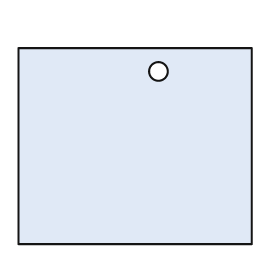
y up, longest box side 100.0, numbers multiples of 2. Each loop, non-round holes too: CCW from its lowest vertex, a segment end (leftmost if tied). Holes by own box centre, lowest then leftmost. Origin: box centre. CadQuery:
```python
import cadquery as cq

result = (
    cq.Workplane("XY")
    .moveTo(-50.0, -42.0)
    .lineTo(50.0, -42.0)
    .lineTo(50.0, 42.0)
    .lineTo(-50.0, 42.0)
    .close()
    .moveTo(10.0, 32.0)
    .circle(4.0)
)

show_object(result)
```